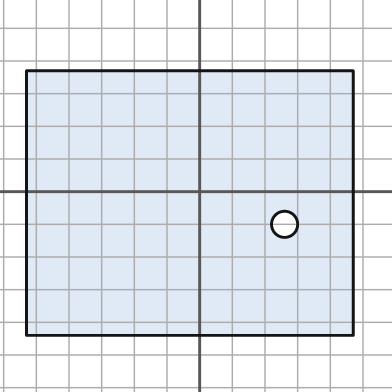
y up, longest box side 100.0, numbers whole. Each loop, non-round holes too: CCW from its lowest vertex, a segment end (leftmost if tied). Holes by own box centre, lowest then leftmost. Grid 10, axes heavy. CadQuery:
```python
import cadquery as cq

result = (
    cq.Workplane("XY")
    .moveTo(-53.0, -44.0)
    .lineTo(47.0, -44.0)
    .lineTo(47.0, 37.0)
    .lineTo(-53.0, 37.0)
    .close()
    .moveTo(26.0, -10.0)
    .circle(4.0)
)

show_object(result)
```